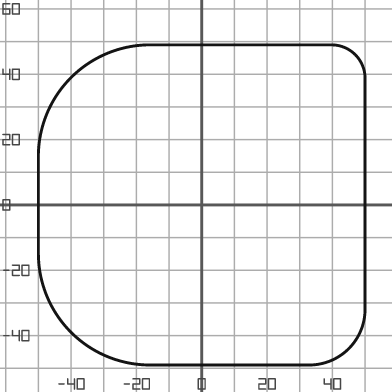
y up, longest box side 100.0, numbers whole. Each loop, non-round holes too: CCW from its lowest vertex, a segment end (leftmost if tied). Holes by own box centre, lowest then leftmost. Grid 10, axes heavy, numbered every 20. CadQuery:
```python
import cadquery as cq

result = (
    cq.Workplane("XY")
    .moveTo(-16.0, -49.0)
    .lineTo(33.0, -49.0)
    .threePointArc((45.0, -44.0), (50.0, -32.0))
    .lineTo(50.0, 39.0)
    .threePointArc((47.0, 46.0), (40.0, 49.0))
    .lineTo(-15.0, 49.0)
    .threePointArc((-40.0, 39.0), (-50.0, 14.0))
    .lineTo(-50.0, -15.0)
    .threePointArc((-40.0, -39.0), (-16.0, -49.0))
    .close()
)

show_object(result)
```